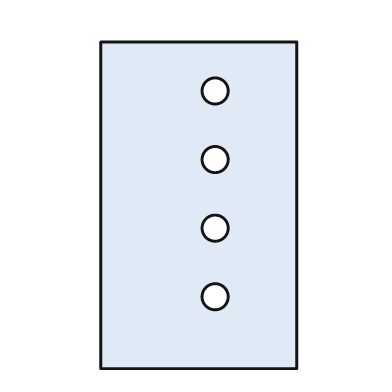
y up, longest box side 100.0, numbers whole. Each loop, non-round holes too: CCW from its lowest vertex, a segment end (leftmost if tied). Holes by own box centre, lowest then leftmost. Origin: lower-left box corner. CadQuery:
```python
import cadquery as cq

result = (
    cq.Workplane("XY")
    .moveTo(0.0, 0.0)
    .lineTo(60.0, 0.0)
    .lineTo(60.0, 100.0)
    .lineTo(0.0, 100.0)
    .close()
    .moveTo(35.0, 22.0)
    .circle(4.0)
    .moveTo(35.0, 43.0)
    .circle(4.0)
    .moveTo(35.0, 64.0)
    .circle(4.0)
    .moveTo(35.0, 85.0)
    .circle(4.0)
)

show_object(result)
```